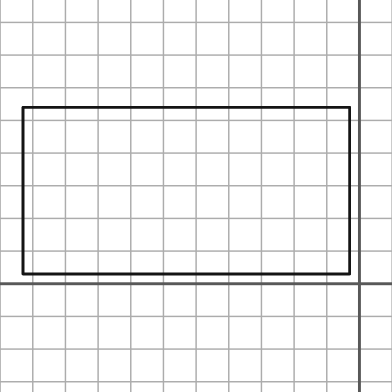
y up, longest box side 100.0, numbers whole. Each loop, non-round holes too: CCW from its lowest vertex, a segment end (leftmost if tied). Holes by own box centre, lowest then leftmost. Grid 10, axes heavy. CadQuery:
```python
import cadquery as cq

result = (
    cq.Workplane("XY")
    .moveTo(-103.0, 3.0)
    .lineTo(-3.0, 3.0)
    .lineTo(-3.0, 54.0)
    .lineTo(-103.0, 54.0)
    .close()
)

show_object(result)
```